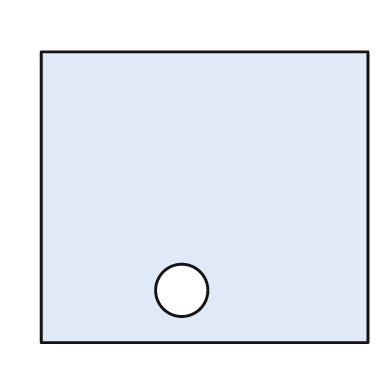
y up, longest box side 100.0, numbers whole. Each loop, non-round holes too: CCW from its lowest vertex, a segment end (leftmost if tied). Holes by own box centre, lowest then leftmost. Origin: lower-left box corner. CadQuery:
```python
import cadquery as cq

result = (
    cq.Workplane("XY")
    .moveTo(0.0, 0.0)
    .lineTo(100.0, 0.0)
    .lineTo(100.0, 89.0)
    .lineTo(0.0, 89.0)
    .close()
    .moveTo(43.0, 16.0)
    .circle(8.0)
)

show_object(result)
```